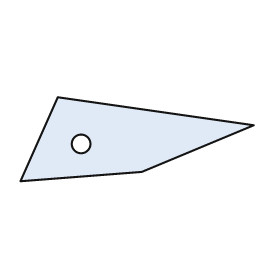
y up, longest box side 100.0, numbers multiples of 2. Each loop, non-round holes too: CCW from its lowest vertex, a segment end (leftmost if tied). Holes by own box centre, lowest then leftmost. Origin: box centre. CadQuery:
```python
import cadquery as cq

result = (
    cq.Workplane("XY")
    .moveTo(-50.0, -18.0)
    .lineTo(2.0, -14.0)
    .lineTo(50.0, 6.0)
    .lineTo(-34.0, 18.0)
    .close()
    .moveTo(-24.0, -2.0)
    .circle(4.0)
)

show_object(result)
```